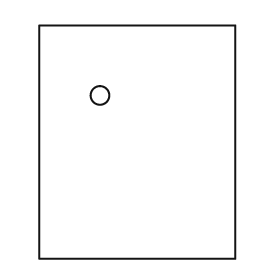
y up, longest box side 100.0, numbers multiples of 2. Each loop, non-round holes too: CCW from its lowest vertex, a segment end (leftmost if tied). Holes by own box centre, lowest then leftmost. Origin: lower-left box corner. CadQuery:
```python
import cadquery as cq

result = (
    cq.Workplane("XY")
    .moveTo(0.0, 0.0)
    .lineTo(84.0, 0.0)
    .lineTo(84.0, 100.0)
    .lineTo(0.0, 100.0)
    .close()
    .moveTo(26.0, 70.0)
    .circle(4.0)
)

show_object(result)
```